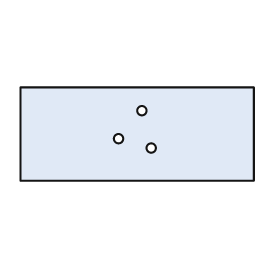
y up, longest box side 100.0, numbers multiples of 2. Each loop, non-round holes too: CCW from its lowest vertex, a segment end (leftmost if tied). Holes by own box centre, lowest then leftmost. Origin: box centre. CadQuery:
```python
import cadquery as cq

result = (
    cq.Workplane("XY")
    .moveTo(-50.0, -20.0)
    .lineTo(50.0, -20.0)
    .lineTo(50.0, 20.0)
    .lineTo(-50.0, 20.0)
    .close()
    .moveTo(6.0, -6.0)
    .circle(2.0)
    .moveTo(-8.0, -2.0)
    .circle(2.0)
    .moveTo(2.0, 10.0)
    .circle(2.0)
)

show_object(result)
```